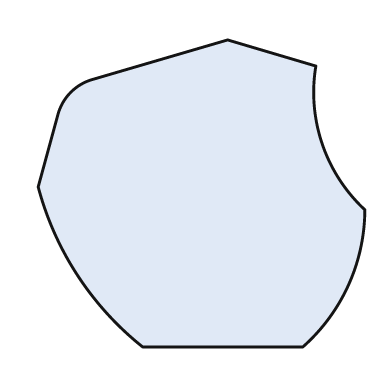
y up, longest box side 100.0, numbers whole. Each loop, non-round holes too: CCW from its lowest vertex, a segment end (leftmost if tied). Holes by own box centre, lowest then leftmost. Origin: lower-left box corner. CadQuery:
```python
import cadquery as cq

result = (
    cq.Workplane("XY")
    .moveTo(32.0, 0.0)
    .lineTo(81.0, 0.0)
    .threePointArc((95.0, 19.0), (100.0, 42.0))
    .threePointArc((87.0, 62.0), (85.0, 86.0))
    .lineTo(58.0, 94.0)
    .lineTo(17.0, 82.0)
    .threePointArc((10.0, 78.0), (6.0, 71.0))
    .lineTo(0.0, 49.0)
    .threePointArc((12.0, 22.0), (32.0, 0.0))
    .close()
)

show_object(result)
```